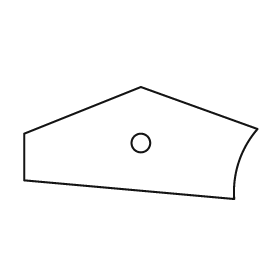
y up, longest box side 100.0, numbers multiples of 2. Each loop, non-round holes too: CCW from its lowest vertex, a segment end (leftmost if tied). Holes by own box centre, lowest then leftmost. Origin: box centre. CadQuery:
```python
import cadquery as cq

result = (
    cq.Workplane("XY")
    .moveTo(40.0, -24.0)
    .threePointArc((42.0, -8.0), (50.0, 6.0))
    .lineTo(0.0, 24.0)
    .lineTo(-50.0, 4.0)
    .lineTo(-50.0, -16.0)
    .close()
    .moveTo(0.0, 0.0)
    .circle(4.0)
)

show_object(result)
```